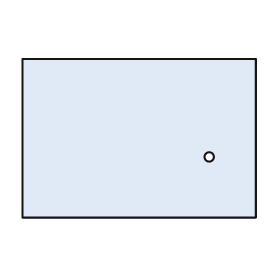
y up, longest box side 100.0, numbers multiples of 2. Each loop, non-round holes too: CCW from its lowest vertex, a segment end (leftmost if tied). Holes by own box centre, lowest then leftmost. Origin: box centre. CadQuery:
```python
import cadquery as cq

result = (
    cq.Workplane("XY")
    .moveTo(-50.0, -34.0)
    .lineTo(50.0, -34.0)
    .lineTo(50.0, 34.0)
    .lineTo(-50.0, 34.0)
    .close()
    .moveTo(30.0, -8.0)
    .circle(2.0)
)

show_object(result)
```